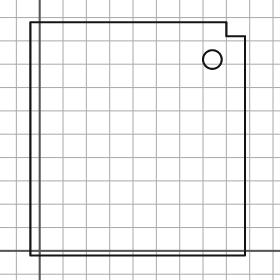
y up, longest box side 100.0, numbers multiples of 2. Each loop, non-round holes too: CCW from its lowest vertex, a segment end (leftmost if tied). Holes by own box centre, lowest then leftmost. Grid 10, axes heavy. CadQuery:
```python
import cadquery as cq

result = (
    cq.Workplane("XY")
    .moveTo(-4.0, -2.0)
    .lineTo(88.0, -2.0)
    .lineTo(88.0, 92.0)
    .lineTo(80.0, 92.0)
    .lineTo(80.0, 98.0)
    .lineTo(-4.0, 98.0)
    .close()
    .moveTo(74.0, 82.0)
    .circle(4.0)
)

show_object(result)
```